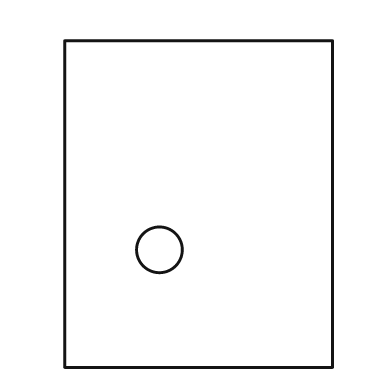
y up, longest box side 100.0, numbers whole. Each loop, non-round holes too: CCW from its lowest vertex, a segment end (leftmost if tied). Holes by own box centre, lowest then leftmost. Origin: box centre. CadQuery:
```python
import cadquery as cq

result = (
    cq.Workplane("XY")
    .moveTo(-41.0, -50.0)
    .lineTo(41.0, -50.0)
    .lineTo(41.0, 50.0)
    .lineTo(-41.0, 50.0)
    .close()
    .moveTo(-12.0, -14.0)
    .circle(7.0)
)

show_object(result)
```